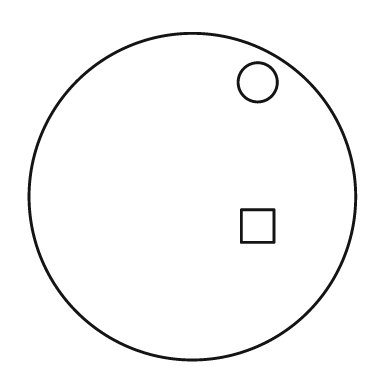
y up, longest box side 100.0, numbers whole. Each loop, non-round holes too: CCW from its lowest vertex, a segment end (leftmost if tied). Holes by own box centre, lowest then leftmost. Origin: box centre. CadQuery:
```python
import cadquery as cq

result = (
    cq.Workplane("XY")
    .moveTo(0.0, 0.0)
    .circle(50.0)
    .moveTo(15.0, -14.0)
    .lineTo(25.0, -14.0)
    .lineTo(25.0, -4.0)
    .lineTo(15.0, -4.0)
    .close()
    .moveTo(20.0, 35.0)
    .circle(6.0)
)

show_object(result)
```